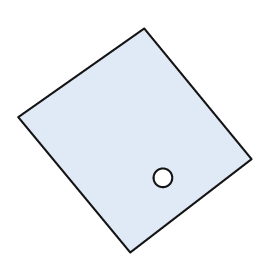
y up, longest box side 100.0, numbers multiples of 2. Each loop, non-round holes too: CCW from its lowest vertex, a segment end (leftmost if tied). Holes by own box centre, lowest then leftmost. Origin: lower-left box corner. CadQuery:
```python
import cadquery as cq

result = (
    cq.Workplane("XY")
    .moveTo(48.0, 0.0)
    .lineTo(100.0, 40.0)
    .lineTo(54.0, 96.0)
    .lineTo(0.0, 58.0)
    .close()
    .moveTo(62.0, 32.0)
    .circle(4.0)
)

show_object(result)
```